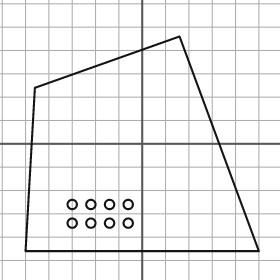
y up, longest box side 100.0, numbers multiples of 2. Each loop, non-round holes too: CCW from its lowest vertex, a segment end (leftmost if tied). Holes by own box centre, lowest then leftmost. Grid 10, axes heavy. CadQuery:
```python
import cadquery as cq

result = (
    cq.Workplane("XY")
    .moveTo(-50.0, -46.0)
    .lineTo(50.0, -46.0)
    .lineTo(16.0, 46.0)
    .lineTo(-46.0, 24.0)
    .close()
    .moveTo(-30.0, -34.0)
    .circle(2.0)
    .moveTo(-22.0, -34.0)
    .circle(2.0)
    .moveTo(-14.0, -34.0)
    .circle(2.0)
    .moveTo(-6.0, -34.0)
    .circle(2.0)
    .moveTo(-30.0, -26.0)
    .circle(2.0)
    .moveTo(-22.0, -26.0)
    .circle(2.0)
    .moveTo(-14.0, -26.0)
    .circle(2.0)
    .moveTo(-6.0, -26.0)
    .circle(2.0)
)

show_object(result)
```